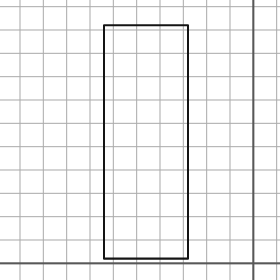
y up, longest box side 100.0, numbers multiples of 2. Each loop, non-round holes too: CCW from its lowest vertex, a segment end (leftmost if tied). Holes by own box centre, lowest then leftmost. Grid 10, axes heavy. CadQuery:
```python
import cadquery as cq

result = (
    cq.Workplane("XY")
    .moveTo(-64.0, 2.0)
    .lineTo(-28.0, 2.0)
    .lineTo(-28.0, 102.0)
    .lineTo(-64.0, 102.0)
    .close()
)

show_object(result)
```